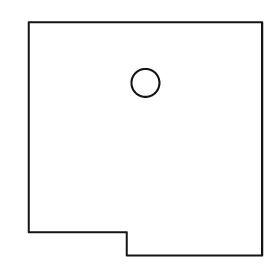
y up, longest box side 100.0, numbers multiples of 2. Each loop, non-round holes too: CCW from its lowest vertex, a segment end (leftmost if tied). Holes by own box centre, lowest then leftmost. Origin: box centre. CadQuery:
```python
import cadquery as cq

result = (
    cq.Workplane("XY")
    .moveTo(-8.0, -50.0)
    .lineTo(50.0, -50.0)
    .lineTo(50.0, 50.0)
    .lineTo(-50.0, 50.0)
    .lineTo(-50.0, -40.0)
    .lineTo(-8.0, -40.0)
    .close()
    .moveTo(0.0, 24.0)
    .circle(6.0)
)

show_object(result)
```